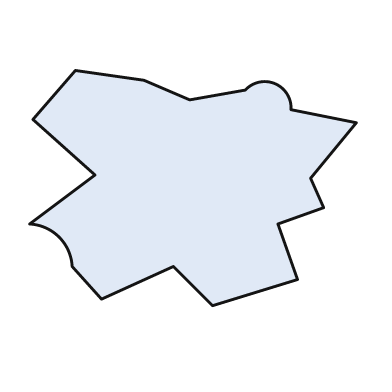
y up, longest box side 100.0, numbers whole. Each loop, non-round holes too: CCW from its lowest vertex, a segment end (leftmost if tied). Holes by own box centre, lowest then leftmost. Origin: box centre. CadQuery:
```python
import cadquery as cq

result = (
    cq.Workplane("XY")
    .moveTo(6.0, -36.0)
    .lineTo(32.0, -28.0)
    .lineTo(26.0, -11.0)
    .lineTo(40.0, -6.0)
    .lineTo(36.0, 3.0)
    .lineTo(50.0, 20.0)
    .lineTo(30.0, 24.0)
    .threePointArc((25.0, 32.0), (16.0, 30.0))
    .lineTo(-1.0, 27.0)
    .lineTo(-15.0, 33.0)
    .lineTo(-36.0, 36.0)
    .lineTo(-49.0, 21.0)
    .lineTo(-30.0, 4.0)
    .lineTo(-50.0, -11.0)
    .threePointArc((-41.0, -15.0), (-37.0, -24.0))
    .lineTo(-28.0, -34.0)
    .lineTo(-6.0, -24.0)
    .close()
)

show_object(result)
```